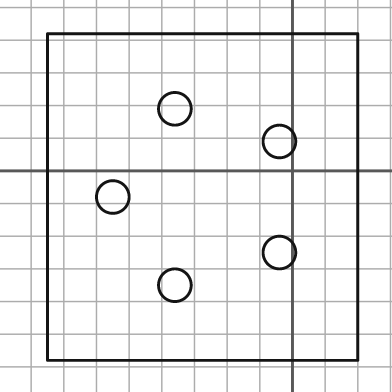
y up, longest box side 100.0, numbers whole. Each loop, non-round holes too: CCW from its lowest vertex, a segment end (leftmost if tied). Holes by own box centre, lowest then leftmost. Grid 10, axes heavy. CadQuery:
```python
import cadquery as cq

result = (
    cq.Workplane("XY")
    .moveTo(-75.0, -58.0)
    .lineTo(20.0, -58.0)
    .lineTo(20.0, 42.0)
    .lineTo(-75.0, 42.0)
    .close()
    .moveTo(-36.0, -35.0)
    .circle(5.0)
    .moveTo(-4.0, -25.0)
    .circle(5.0)
    .moveTo(-55.0, -8.0)
    .circle(5.0)
    .moveTo(-4.0, 9.0)
    .circle(5.0)
    .moveTo(-36.0, 19.0)
    .circle(5.0)
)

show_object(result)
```